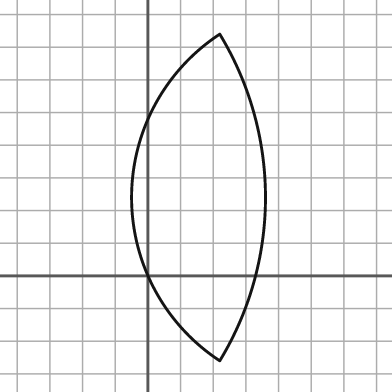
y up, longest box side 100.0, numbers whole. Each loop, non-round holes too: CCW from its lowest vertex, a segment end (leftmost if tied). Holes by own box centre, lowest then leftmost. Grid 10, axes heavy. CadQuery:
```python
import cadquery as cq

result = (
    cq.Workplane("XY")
    .moveTo(22.0, -26.0)
    .threePointArc((36.0, 24.0), (22.0, 74.0))
    .threePointArc((-5.0, 24.0), (22.0, -26.0))
    .close()
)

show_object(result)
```